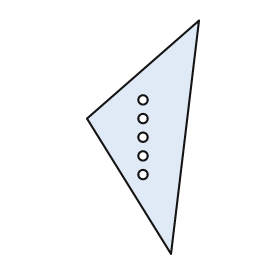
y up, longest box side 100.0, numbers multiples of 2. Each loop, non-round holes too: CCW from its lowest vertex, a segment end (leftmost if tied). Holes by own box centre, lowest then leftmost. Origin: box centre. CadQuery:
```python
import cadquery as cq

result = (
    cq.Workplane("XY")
    .moveTo(12.0, -50.0)
    .lineTo(24.0, 50.0)
    .lineTo(-24.0, 8.0)
    .close()
    .moveTo(0.0, -16.0)
    .circle(2.0)
    .moveTo(0.0, -8.0)
    .circle(2.0)
    .moveTo(0.0, 0.0)
    .circle(2.0)
    .moveTo(0.0, 8.0)
    .circle(2.0)
    .moveTo(0.0, 16.0)
    .circle(2.0)
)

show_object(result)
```